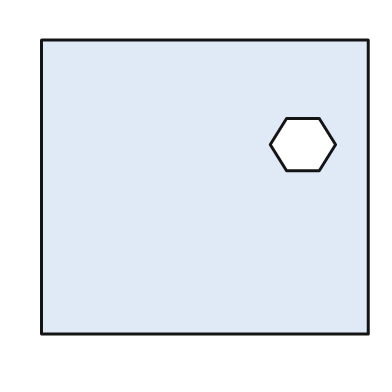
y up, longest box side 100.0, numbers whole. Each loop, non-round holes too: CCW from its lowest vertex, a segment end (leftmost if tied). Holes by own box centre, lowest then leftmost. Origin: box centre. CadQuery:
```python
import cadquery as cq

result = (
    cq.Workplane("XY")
    .moveTo(-50.0, -45.0)
    .lineTo(50.0, -45.0)
    .lineTo(50.0, 45.0)
    .lineTo(-50.0, 45.0)
    .close()
    .moveTo(25.0, 5.0)
    .lineTo(35.0, 5.0)
    .lineTo(40.0, 13.0)
    .lineTo(35.0, 21.0)
    .lineTo(25.0, 21.0)
    .lineTo(20.0, 13.0)
    .close()
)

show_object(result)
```